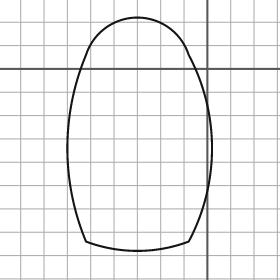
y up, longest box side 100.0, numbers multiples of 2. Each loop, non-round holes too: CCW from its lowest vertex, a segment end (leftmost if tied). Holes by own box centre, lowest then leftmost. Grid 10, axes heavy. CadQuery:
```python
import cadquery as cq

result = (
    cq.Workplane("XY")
    .moveTo(-52.0, -74.0)
    .threePointArc((-30.0, -78.0), (-8.0, -74.0))
    .threePointArc((2.0, -34.0), (-8.0, 6.0))
    .threePointArc((-30.0, 22.0), (-52.0, 6.0))
    .threePointArc((-60.0, -34.0), (-52.0, -74.0))
    .close()
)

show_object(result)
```